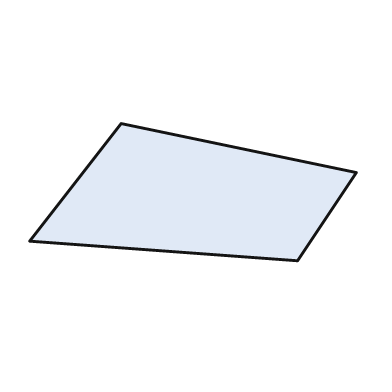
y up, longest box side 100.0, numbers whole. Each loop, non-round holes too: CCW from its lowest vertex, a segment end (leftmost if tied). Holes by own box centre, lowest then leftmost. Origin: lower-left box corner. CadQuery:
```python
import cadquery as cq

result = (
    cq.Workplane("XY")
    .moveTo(82.0, 0.0)
    .lineTo(100.0, 27.0)
    .lineTo(28.0, 42.0)
    .lineTo(0.0, 6.0)
    .close()
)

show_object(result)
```